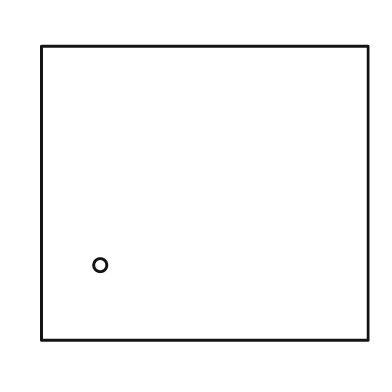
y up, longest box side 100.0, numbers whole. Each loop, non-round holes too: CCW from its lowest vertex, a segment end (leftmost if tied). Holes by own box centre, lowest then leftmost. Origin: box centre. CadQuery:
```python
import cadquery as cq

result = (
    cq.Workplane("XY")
    .moveTo(-50.0, -45.0)
    .lineTo(50.0, -45.0)
    .lineTo(50.0, 45.0)
    .lineTo(-50.0, 45.0)
    .close()
    .moveTo(-32.0, -22.0)
    .circle(2.0)
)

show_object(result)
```